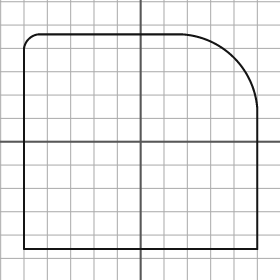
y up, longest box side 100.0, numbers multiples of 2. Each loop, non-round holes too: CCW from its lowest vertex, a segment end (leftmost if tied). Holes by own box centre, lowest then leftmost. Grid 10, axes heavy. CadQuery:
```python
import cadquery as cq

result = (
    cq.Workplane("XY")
    .moveTo(-50.0, -46.0)
    .lineTo(50.0, -46.0)
    .lineTo(50.0, 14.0)
    .threePointArc((40.0, 36.0), (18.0, 46.0))
    .lineTo(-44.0, 46.0)
    .threePointArc((-48.0, 44.0), (-50.0, 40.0))
    .close()
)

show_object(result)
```